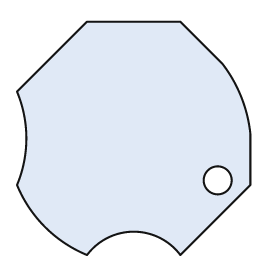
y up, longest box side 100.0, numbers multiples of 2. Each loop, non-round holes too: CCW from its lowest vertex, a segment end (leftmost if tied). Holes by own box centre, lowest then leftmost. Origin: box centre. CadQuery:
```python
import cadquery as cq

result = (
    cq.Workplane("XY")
    .moveTo(-20.0, -50.0)
    .threePointArc((0.0, -40.0), (20.0, -50.0))
    .lineTo(50.0, -20.0)
    .lineTo(50.0, 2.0)
    .threePointArc((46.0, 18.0), (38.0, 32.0))
    .lineTo(20.0, 50.0)
    .lineTo(-20.0, 50.0)
    .lineTo(-50.0, 20.0)
    .threePointArc((-46.0, 0.0), (-50.0, -20.0))
    .threePointArc((-38.0, -38.0), (-20.0, -50.0))
    .close()
    .moveTo(36.0, -18.0)
    .circle(6.0)
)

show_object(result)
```